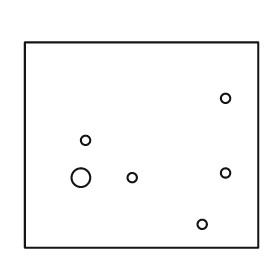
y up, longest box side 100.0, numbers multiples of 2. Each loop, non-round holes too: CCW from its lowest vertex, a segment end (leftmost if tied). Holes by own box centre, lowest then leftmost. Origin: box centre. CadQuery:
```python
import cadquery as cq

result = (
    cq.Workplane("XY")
    .moveTo(-50.0, -44.0)
    .lineTo(50.0, -44.0)
    .lineTo(50.0, 44.0)
    .lineTo(-50.0, 44.0)
    .close()
    .moveTo(26.0, -34.0)
    .circle(2.0)
    .moveTo(-26.0, -14.0)
    .circle(4.0)
    .moveTo(-4.0, -14.0)
    .circle(2.0)
    .moveTo(36.0, -12.0)
    .circle(2.0)
    .moveTo(-24.0, 2.0)
    .circle(2.0)
    .moveTo(36.0, 20.0)
    .circle(2.0)
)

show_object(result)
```